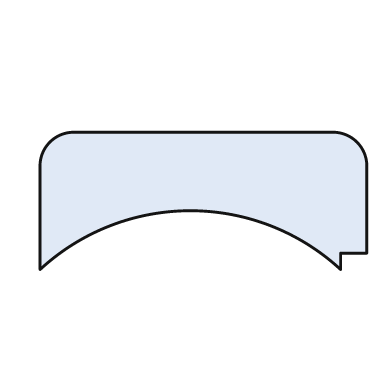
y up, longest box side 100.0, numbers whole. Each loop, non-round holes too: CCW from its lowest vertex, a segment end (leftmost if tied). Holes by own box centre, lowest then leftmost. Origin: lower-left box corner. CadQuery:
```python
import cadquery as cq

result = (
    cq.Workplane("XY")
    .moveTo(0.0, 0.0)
    .threePointArc((46.0, 18.0), (92.0, 0.0))
    .lineTo(92.0, 5.0)
    .lineTo(100.0, 5.0)
    .lineTo(100.0, 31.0)
    .threePointArc((97.0, 39.0), (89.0, 42.0))
    .lineTo(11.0, 42.0)
    .threePointArc((3.0, 39.0), (0.0, 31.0))
    .close()
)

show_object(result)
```